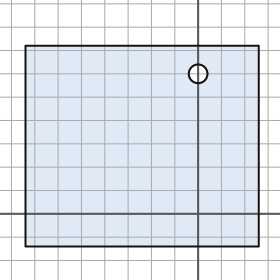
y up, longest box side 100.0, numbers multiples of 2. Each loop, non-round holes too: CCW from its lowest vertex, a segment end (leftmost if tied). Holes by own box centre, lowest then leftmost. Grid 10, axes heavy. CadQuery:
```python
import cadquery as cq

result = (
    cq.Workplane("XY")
    .moveTo(-74.0, -14.0)
    .lineTo(26.0, -14.0)
    .lineTo(26.0, 72.0)
    .lineTo(-74.0, 72.0)
    .close()
    .moveTo(0.0, 60.0)
    .circle(4.0)
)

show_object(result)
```